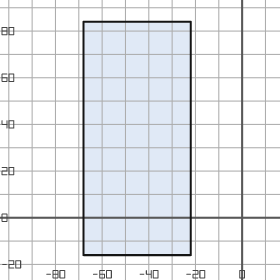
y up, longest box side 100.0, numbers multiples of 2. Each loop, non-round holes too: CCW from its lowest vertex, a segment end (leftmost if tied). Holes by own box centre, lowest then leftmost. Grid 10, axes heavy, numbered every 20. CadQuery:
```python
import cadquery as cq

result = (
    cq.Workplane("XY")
    .moveTo(-68.0, -16.0)
    .lineTo(-22.0, -16.0)
    .lineTo(-22.0, 84.0)
    .lineTo(-68.0, 84.0)
    .close()
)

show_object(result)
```